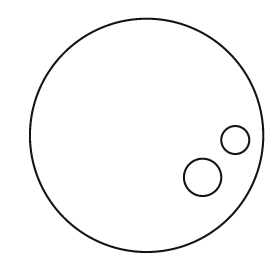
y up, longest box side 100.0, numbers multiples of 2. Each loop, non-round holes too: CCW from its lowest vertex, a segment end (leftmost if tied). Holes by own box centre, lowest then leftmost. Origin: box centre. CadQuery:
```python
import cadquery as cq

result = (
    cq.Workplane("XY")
    .moveTo(0.0, 0.0)
    .circle(50.0)
    .moveTo(24.0, -18.0)
    .circle(8.0)
    .moveTo(38.0, -2.0)
    .circle(6.0)
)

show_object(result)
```